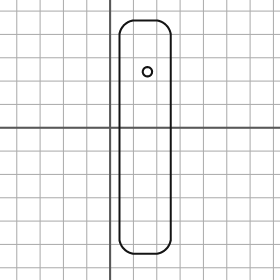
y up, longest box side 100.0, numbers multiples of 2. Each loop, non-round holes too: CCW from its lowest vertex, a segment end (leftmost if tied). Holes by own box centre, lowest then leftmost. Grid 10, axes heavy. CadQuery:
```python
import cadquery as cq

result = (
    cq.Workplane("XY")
    .moveTo(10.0, -54.0)
    .lineTo(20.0, -54.0)
    .threePointArc((24.0, -52.0), (26.0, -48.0))
    .lineTo(26.0, 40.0)
    .threePointArc((24.0, 44.0), (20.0, 46.0))
    .lineTo(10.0, 46.0)
    .threePointArc((6.0, 44.0), (4.0, 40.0))
    .lineTo(4.0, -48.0)
    .threePointArc((6.0, -52.0), (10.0, -54.0))
    .close()
    .moveTo(16.0, 24.0)
    .circle(2.0)
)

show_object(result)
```